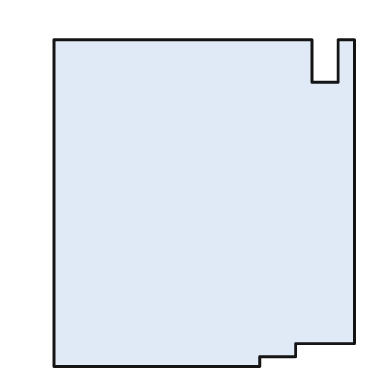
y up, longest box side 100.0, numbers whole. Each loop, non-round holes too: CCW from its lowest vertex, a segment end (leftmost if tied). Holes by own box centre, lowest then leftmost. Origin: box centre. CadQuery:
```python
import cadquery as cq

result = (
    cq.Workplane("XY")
    .moveTo(-46.0, -50.0)
    .lineTo(17.0, -50.0)
    .lineTo(17.0, -47.0)
    .lineTo(28.0, -47.0)
    .lineTo(28.0, -43.0)
    .lineTo(46.0, -43.0)
    .lineTo(46.0, 50.0)
    .lineTo(41.0, 50.0)
    .lineTo(41.0, 37.0)
    .lineTo(33.0, 37.0)
    .lineTo(33.0, 50.0)
    .lineTo(-46.0, 50.0)
    .close()
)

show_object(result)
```